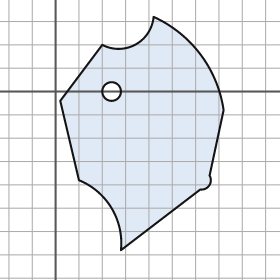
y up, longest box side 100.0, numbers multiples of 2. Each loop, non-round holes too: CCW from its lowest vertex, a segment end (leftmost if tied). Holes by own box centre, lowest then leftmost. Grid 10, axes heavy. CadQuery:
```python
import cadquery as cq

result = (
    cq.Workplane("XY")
    .moveTo(28.0, -68.0)
    .lineTo(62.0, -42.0)
    .threePointArc((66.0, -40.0), (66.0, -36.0))
    .lineTo(72.0, -8.0)
    .threePointArc((62.0, 16.0), (42.0, 32.0))
    .threePointArc((34.0, 20.0), (20.0, 20.0))
    .lineTo(2.0, -4.0)
    .lineTo(10.0, -38.0)
    .threePointArc((24.0, -50.0), (28.0, -68.0))
    .close()
    .moveTo(24.0, 0.0)
    .circle(4.0)
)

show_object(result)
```